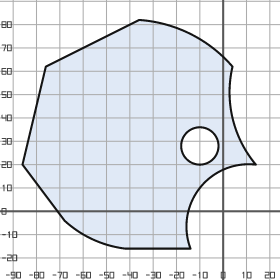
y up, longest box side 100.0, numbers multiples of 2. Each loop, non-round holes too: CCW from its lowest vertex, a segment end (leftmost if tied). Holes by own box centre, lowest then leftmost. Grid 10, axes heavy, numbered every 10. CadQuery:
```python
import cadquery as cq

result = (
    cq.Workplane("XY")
    .moveTo(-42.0, -16.0)
    .lineTo(-14.0, -16.0)
    .threePointArc((-10.0, 10.0), (14.0, 20.0))
    .threePointArc((4.0, 40.0), (4.0, 62.0))
    .threePointArc((-14.0, 76.0), (-36.0, 82.0))
    .lineTo(-76.0, 62.0)
    .lineTo(-86.0, 20.0)
    .lineTo(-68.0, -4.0)
    .threePointArc((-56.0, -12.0), (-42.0, -16.0))
    .close()
    .moveTo(-10.0, 28.0)
    .circle(8.0)
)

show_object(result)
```